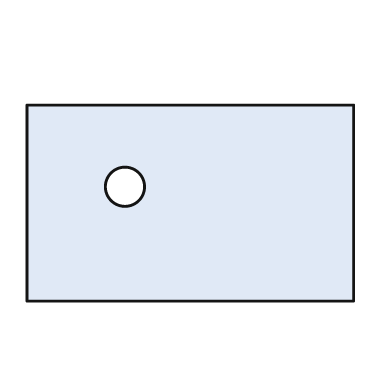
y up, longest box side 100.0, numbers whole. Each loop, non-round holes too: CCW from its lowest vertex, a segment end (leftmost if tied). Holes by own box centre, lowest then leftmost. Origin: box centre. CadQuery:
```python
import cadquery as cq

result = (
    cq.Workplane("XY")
    .moveTo(-50.0, -30.0)
    .lineTo(50.0, -30.0)
    .lineTo(50.0, 30.0)
    .lineTo(-50.0, 30.0)
    .close()
    .moveTo(-20.0, 5.0)
    .circle(6.0)
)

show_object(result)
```